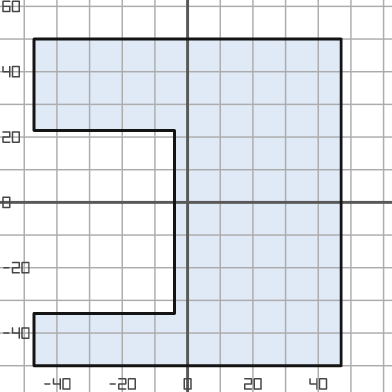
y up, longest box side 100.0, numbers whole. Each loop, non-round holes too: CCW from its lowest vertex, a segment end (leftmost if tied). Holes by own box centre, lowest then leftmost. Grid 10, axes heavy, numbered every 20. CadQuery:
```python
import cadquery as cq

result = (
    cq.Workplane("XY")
    .moveTo(-47.0, -50.0)
    .lineTo(47.0, -50.0)
    .lineTo(47.0, 50.0)
    .lineTo(-47.0, 50.0)
    .lineTo(-47.0, 22.0)
    .lineTo(-4.0, 22.0)
    .lineTo(-4.0, -34.0)
    .lineTo(-47.0, -34.0)
    .close()
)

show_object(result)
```